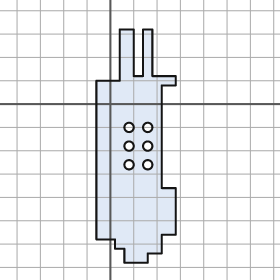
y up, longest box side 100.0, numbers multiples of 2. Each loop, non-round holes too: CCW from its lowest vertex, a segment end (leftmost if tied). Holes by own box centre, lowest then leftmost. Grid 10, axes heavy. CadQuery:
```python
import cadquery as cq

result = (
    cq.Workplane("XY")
    .moveTo(6.0, -68.0)
    .lineTo(16.0, -68.0)
    .lineTo(16.0, -64.0)
    .lineTo(22.0, -64.0)
    .lineTo(22.0, -56.0)
    .lineTo(28.0, -56.0)
    .lineTo(28.0, -36.0)
    .lineTo(22.0, -36.0)
    .lineTo(22.0, 8.0)
    .lineTo(28.0, 8.0)
    .lineTo(28.0, 12.0)
    .lineTo(18.0, 12.0)
    .lineTo(18.0, 32.0)
    .lineTo(14.0, 32.0)
    .lineTo(14.0, 12.0)
    .lineTo(10.0, 12.0)
    .lineTo(10.0, 32.0)
    .lineTo(4.0, 32.0)
    .lineTo(4.0, 10.0)
    .lineTo(-6.0, 10.0)
    .lineTo(-6.0, -58.0)
    .lineTo(2.0, -58.0)
    .lineTo(2.0, -62.0)
    .lineTo(6.0, -62.0)
    .close()
    .moveTo(8.0, -26.0)
    .circle(2.0)
    .moveTo(16.0, -26.0)
    .circle(2.0)
    .moveTo(8.0, -18.0)
    .circle(2.0)
    .moveTo(16.0, -18.0)
    .circle(2.0)
    .moveTo(8.0, -10.0)
    .circle(2.0)
    .moveTo(16.0, -10.0)
    .circle(2.0)
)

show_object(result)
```